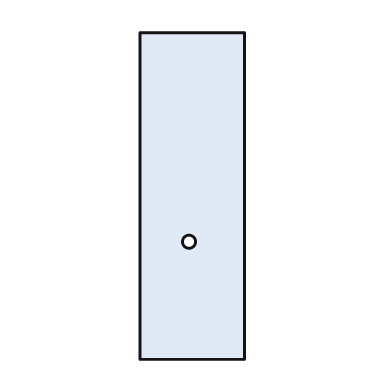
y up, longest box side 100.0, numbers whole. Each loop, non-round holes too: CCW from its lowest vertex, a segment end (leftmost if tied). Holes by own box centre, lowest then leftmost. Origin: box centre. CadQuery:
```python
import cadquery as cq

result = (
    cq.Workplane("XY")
    .moveTo(-16.0, -50.0)
    .lineTo(16.0, -50.0)
    .lineTo(16.0, 50.0)
    .lineTo(-16.0, 50.0)
    .close()
    .moveTo(-1.0, -14.0)
    .circle(2.0)
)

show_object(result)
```